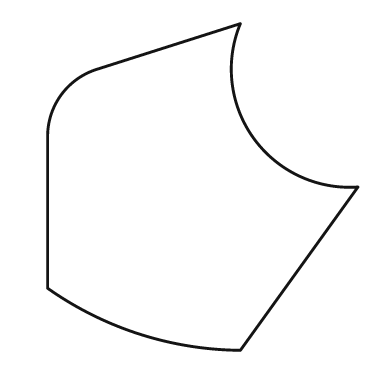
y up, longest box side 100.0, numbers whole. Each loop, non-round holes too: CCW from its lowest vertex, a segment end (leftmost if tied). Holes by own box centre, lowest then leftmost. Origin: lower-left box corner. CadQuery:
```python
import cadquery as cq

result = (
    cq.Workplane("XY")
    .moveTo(59.0, 0.0)
    .lineTo(95.0, 50.0)
    .threePointArc((63.0, 65.0), (59.0, 100.0))
    .lineTo(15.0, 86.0)
    .threePointArc((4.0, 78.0), (0.0, 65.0))
    .lineTo(0.0, 19.0)
    .threePointArc((28.0, 5.0), (59.0, 0.0))
    .close()
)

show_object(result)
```